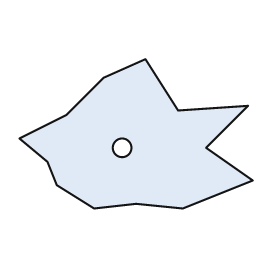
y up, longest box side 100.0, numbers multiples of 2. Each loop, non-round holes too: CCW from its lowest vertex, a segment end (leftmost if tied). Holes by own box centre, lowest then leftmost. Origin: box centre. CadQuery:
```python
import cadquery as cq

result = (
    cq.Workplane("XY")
    .moveTo(-18.0, -32.0)
    .lineTo(0.0, -30.0)
    .lineTo(20.0, -32.0)
    .lineTo(50.0, -20.0)
    .lineTo(30.0, -6.0)
    .lineTo(48.0, 12.0)
    .lineTo(18.0, 10.0)
    .lineTo(4.0, 32.0)
    .lineTo(-14.0, 24.0)
    .lineTo(-30.0, 8.0)
    .lineTo(-50.0, -2.0)
    .lineTo(-38.0, -12.0)
    .lineTo(-34.0, -22.0)
    .close()
    .moveTo(-6.0, -6.0)
    .circle(4.0)
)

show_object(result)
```